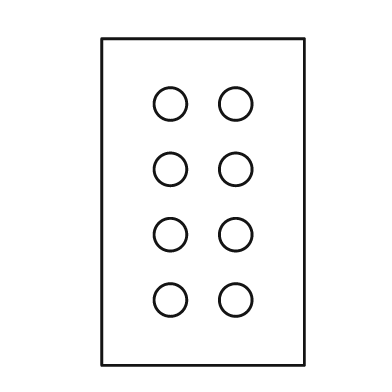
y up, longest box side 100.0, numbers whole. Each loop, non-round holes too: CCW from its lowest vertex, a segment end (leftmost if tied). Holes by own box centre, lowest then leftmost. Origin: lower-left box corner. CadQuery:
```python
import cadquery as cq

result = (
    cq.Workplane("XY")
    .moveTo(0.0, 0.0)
    .lineTo(62.0, 0.0)
    .lineTo(62.0, 100.0)
    .lineTo(0.0, 100.0)
    .close()
    .moveTo(21.0, 20.0)
    .circle(5.0)
    .moveTo(41.0, 20.0)
    .circle(5.0)
    .moveTo(21.0, 40.0)
    .circle(5.0)
    .moveTo(41.0, 40.0)
    .circle(5.0)
    .moveTo(21.0, 60.0)
    .circle(5.0)
    .moveTo(41.0, 60.0)
    .circle(5.0)
    .moveTo(21.0, 80.0)
    .circle(5.0)
    .moveTo(41.0, 80.0)
    .circle(5.0)
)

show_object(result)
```